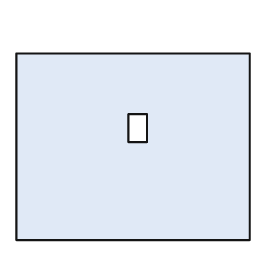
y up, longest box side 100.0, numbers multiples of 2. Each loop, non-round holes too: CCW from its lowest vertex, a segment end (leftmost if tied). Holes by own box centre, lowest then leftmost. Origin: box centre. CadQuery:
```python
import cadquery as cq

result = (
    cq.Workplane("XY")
    .moveTo(-50.0, -40.0)
    .lineTo(50.0, -40.0)
    .lineTo(50.0, 40.0)
    .lineTo(-50.0, 40.0)
    .close()
    .moveTo(-2.0, 2.0)
    .lineTo(6.0, 2.0)
    .lineTo(6.0, 14.0)
    .lineTo(-2.0, 14.0)
    .close()
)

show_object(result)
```